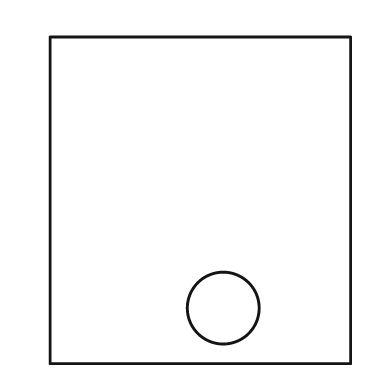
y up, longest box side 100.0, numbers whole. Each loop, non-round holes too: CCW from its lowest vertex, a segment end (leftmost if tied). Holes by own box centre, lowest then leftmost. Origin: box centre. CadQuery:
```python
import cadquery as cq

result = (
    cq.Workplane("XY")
    .moveTo(-46.0, -50.0)
    .lineTo(46.0, -50.0)
    .lineTo(46.0, 50.0)
    .lineTo(-46.0, 50.0)
    .close()
    .moveTo(7.0, -33.0)
    .circle(11.0)
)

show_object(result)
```